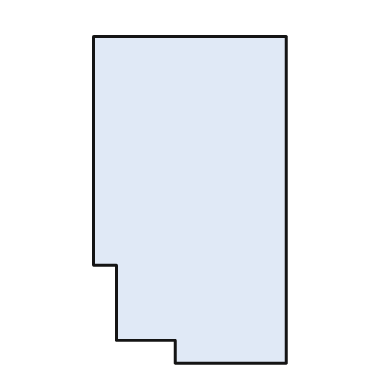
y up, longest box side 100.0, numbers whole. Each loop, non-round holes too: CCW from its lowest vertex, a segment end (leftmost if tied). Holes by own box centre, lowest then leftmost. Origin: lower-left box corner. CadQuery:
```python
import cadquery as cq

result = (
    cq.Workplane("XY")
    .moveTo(25.0, 0.0)
    .lineTo(59.0, 0.0)
    .lineTo(59.0, 100.0)
    .lineTo(0.0, 100.0)
    .lineTo(0.0, 30.0)
    .lineTo(7.0, 30.0)
    .lineTo(7.0, 7.0)
    .lineTo(25.0, 7.0)
    .close()
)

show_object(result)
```